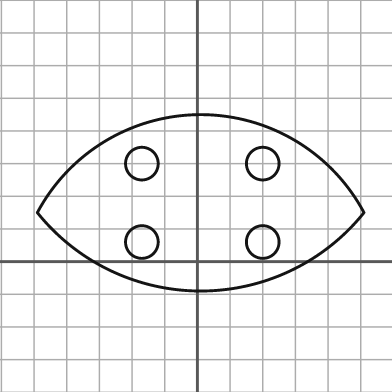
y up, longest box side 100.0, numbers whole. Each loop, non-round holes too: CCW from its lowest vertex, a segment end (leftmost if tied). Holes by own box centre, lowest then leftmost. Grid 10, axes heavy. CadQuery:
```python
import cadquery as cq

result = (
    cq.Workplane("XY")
    .moveTo(-49.0, 15.0)
    .threePointArc((1.0, -9.0), (51.0, 15.0))
    .threePointArc((1.0, 45.0), (-49.0, 15.0))
    .close()
    .moveTo(-17.0, 6.0)
    .circle(5.0)
    .moveTo(20.0, 6.0)
    .circle(5.0)
    .moveTo(-17.0, 30.0)
    .circle(5.0)
    .moveTo(20.0, 30.0)
    .circle(5.0)
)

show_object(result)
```